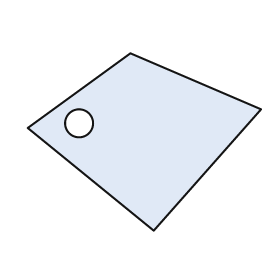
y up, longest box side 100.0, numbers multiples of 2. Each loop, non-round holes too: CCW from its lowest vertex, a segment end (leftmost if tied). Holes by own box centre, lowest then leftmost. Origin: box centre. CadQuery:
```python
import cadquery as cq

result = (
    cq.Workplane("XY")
    .moveTo(4.0, -38.0)
    .lineTo(50.0, 14.0)
    .lineTo(-6.0, 38.0)
    .lineTo(-50.0, 6.0)
    .close()
    .moveTo(-28.0, 8.0)
    .circle(6.0)
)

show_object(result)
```